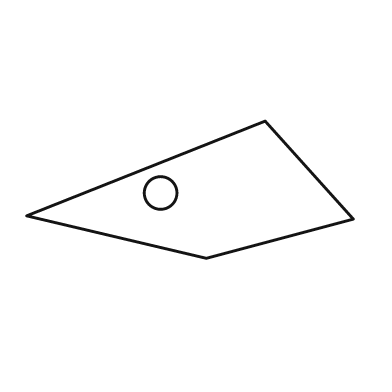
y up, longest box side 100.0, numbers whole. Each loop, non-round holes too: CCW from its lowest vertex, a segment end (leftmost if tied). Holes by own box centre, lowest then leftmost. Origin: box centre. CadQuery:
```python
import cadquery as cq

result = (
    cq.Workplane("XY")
    .moveTo(5.0, -21.0)
    .lineTo(50.0, -9.0)
    .lineTo(23.0, 21.0)
    .lineTo(-50.0, -8.0)
    .close()
    .moveTo(-9.0, -1.0)
    .circle(5.0)
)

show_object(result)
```